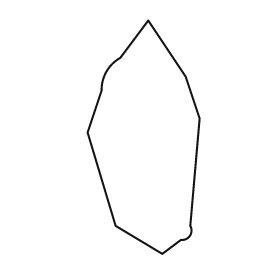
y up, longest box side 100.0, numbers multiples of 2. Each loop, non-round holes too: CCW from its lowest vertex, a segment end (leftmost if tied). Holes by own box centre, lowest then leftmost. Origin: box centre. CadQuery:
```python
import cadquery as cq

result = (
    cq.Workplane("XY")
    .moveTo(8.0, -50.0)
    .lineTo(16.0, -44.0)
    .threePointArc((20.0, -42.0), (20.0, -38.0))
    .lineTo(24.0, 8.0)
    .lineTo(18.0, 26.0)
    .lineTo(2.0, 50.0)
    .lineTo(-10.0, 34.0)
    .threePointArc((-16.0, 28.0), (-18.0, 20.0))
    .lineTo(-24.0, 2.0)
    .lineTo(-12.0, -38.0)
    .close()
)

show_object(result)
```